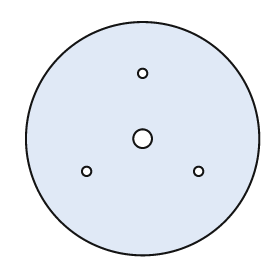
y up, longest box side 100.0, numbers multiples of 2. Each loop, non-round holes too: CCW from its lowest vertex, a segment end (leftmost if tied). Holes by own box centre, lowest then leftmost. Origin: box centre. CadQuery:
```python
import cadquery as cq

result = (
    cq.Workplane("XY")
    .moveTo(0.0, 0.0)
    .circle(50.0)
    .moveTo(-24.0, -14.0)
    .circle(2.0)
    .moveTo(24.0, -14.0)
    .circle(2.0)
    .moveTo(0.0, 0.0)
    .circle(4.0)
    .moveTo(0.0, 28.0)
    .circle(2.0)
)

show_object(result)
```